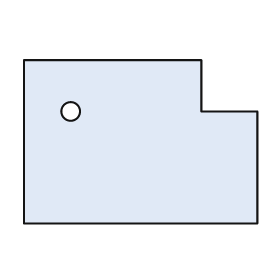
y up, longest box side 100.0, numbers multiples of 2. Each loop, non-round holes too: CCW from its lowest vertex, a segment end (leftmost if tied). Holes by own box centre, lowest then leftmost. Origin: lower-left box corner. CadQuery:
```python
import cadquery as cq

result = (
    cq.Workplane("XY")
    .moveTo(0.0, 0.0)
    .lineTo(100.0, 0.0)
    .lineTo(100.0, 48.0)
    .lineTo(76.0, 48.0)
    .lineTo(76.0, 70.0)
    .lineTo(0.0, 70.0)
    .close()
    .moveTo(20.0, 48.0)
    .circle(4.0)
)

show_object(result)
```